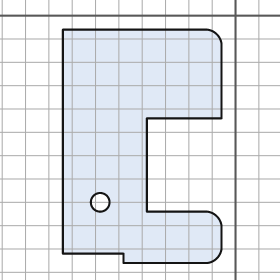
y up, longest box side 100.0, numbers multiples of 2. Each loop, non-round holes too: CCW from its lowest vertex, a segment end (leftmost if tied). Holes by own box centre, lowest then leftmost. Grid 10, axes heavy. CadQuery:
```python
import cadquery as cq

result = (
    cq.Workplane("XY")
    .moveTo(-48.0, -106.0)
    .lineTo(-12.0, -106.0)
    .threePointArc((-8.0, -104.0), (-6.0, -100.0))
    .lineTo(-6.0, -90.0)
    .threePointArc((-8.0, -86.0), (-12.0, -84.0))
    .lineTo(-38.0, -84.0)
    .lineTo(-38.0, -44.0)
    .lineTo(-6.0, -44.0)
    .lineTo(-6.0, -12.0)
    .threePointArc((-8.0, -8.0), (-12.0, -6.0))
    .lineTo(-74.0, -6.0)
    .lineTo(-74.0, -102.0)
    .lineTo(-48.0, -102.0)
    .close()
    .moveTo(-58.0, -80.0)
    .circle(4.0)
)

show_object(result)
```